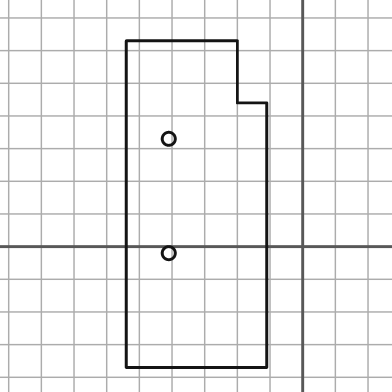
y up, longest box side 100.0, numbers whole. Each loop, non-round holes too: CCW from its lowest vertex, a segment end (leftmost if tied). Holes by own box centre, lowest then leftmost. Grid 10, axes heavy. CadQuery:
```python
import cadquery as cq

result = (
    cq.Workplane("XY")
    .moveTo(-54.0, -37.0)
    .lineTo(-11.0, -37.0)
    .lineTo(-11.0, 44.0)
    .lineTo(-20.0, 44.0)
    .lineTo(-20.0, 63.0)
    .lineTo(-54.0, 63.0)
    .close()
    .moveTo(-41.0, -2.0)
    .circle(2.0)
    .moveTo(-41.0, 33.0)
    .circle(2.0)
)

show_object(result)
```